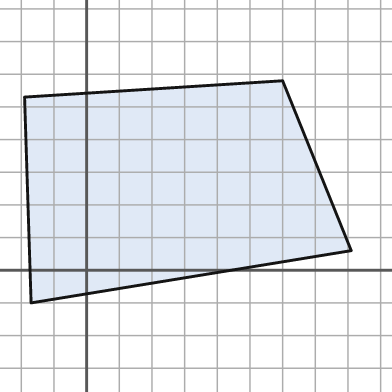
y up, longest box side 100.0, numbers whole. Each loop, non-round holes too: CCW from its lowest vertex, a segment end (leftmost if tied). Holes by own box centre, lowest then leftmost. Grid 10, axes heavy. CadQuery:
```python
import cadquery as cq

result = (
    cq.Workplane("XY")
    .moveTo(-17.0, -10.0)
    .lineTo(81.0, 6.0)
    .lineTo(60.0, 58.0)
    .lineTo(-19.0, 53.0)
    .close()
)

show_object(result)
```